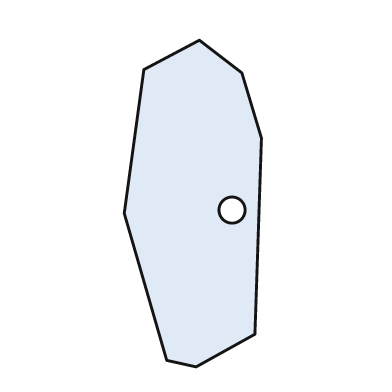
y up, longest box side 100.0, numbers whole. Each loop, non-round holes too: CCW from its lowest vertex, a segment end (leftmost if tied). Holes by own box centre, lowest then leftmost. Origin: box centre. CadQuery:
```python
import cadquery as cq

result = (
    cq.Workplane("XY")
    .moveTo(1.0, -50.0)
    .lineTo(19.0, -40.0)
    .lineTo(21.0, 20.0)
    .lineTo(15.0, 40.0)
    .lineTo(2.0, 50.0)
    .lineTo(-15.0, 41.0)
    .lineTo(-21.0, -3.0)
    .lineTo(-8.0, -48.0)
    .close()
    .moveTo(12.0, -2.0)
    .circle(4.0)
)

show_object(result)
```